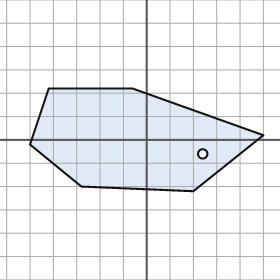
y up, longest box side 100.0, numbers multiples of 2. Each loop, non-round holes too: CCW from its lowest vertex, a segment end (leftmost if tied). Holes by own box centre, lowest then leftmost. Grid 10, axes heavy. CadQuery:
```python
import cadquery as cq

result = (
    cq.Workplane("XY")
    .moveTo(20.0, -22.0)
    .lineTo(50.0, 2.0)
    .lineTo(-6.0, 22.0)
    .lineTo(-42.0, 22.0)
    .lineTo(-50.0, -2.0)
    .lineTo(-28.0, -20.0)
    .close()
    .moveTo(24.0, -6.0)
    .circle(2.0)
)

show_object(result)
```